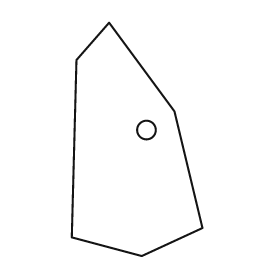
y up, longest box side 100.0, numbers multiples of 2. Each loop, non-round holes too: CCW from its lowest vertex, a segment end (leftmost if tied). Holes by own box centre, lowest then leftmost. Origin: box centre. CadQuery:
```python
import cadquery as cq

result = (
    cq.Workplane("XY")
    .moveTo(2.0, -50.0)
    .lineTo(28.0, -38.0)
    .lineTo(16.0, 12.0)
    .lineTo(-12.0, 50.0)
    .lineTo(-26.0, 34.0)
    .lineTo(-28.0, -42.0)
    .close()
    .moveTo(4.0, 4.0)
    .circle(4.0)
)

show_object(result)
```